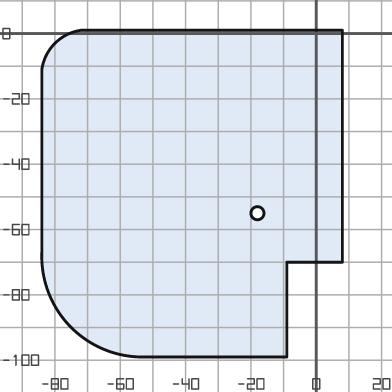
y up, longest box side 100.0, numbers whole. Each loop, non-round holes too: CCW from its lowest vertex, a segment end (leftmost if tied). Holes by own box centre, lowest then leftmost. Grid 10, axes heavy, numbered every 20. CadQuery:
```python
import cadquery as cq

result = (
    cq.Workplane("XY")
    .moveTo(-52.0, -99.0)
    .lineTo(-9.0, -99.0)
    .lineTo(-9.0, -70.0)
    .lineTo(8.0, -70.0)
    .lineTo(8.0, 1.0)
    .lineTo(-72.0, 1.0)
    .threePointArc((-80.0, -3.0), (-84.0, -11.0))
    .lineTo(-84.0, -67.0)
    .threePointArc((-75.0, -90.0), (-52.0, -99.0))
    .close()
    .moveTo(-18.0, -55.0)
    .circle(2.0)
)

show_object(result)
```